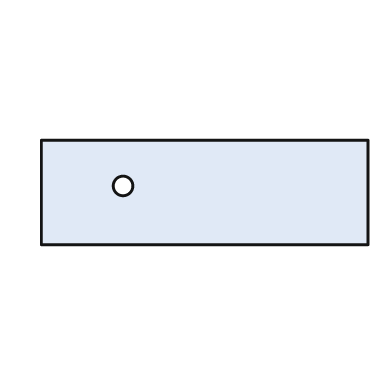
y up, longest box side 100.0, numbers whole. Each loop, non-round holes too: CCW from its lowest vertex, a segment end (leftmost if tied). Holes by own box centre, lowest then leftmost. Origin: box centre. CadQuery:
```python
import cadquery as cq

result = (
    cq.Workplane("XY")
    .moveTo(-50.0, -16.0)
    .lineTo(50.0, -16.0)
    .lineTo(50.0, 16.0)
    .lineTo(-50.0, 16.0)
    .close()
    .moveTo(-25.0, 2.0)
    .circle(3.0)
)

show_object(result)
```